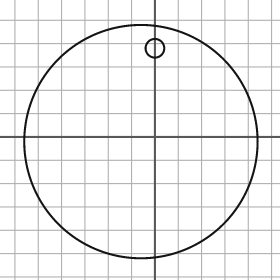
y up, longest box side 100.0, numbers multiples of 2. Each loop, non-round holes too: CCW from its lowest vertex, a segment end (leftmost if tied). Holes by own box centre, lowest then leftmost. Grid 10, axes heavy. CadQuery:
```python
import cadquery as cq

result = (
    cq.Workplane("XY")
    .moveTo(-6.0, -2.0)
    .circle(50.0)
    .moveTo(0.0, 38.0)
    .circle(4.0)
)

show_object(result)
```